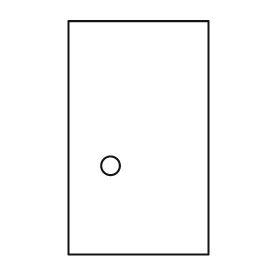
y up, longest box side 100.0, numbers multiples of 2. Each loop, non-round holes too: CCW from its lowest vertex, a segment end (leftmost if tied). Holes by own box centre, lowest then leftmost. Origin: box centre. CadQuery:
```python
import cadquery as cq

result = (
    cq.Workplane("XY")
    .moveTo(-30.0, -50.0)
    .lineTo(30.0, -50.0)
    .lineTo(30.0, 50.0)
    .lineTo(-30.0, 50.0)
    .close()
    .moveTo(-12.0, -12.0)
    .circle(4.0)
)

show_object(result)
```